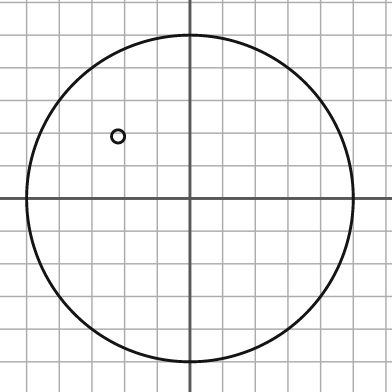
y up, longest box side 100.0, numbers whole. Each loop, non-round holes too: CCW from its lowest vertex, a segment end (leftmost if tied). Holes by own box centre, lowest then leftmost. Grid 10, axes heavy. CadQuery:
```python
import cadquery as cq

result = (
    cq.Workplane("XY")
    .moveTo(0.0, 0.0)
    .circle(50.0)
    .moveTo(-22.0, 19.0)
    .circle(2.0)
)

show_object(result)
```